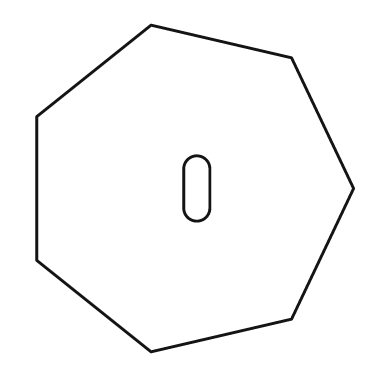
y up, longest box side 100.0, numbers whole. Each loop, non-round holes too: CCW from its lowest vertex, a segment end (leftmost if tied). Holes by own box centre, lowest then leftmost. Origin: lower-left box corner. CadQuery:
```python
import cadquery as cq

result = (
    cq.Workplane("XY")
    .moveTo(35.0, 0.0)
    .lineTo(78.0, 10.0)
    .lineTo(97.0, 50.0)
    .lineTo(78.0, 90.0)
    .lineTo(35.0, 100.0)
    .lineTo(0.0, 72.0)
    .lineTo(0.0, 28.0)
    .close()
    .moveTo(45.0, 44.0)
    .threePointArc((49.0, 40.0), (53.0, 44.0))
    .lineTo(53.0, 56.0)
    .threePointArc((49.0, 60.0), (45.0, 56.0))
    .close()
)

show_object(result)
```